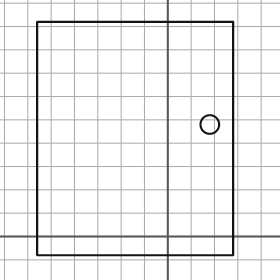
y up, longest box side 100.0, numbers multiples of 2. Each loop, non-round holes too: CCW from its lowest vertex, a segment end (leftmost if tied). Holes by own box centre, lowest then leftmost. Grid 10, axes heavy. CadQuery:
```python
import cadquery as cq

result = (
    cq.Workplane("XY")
    .moveTo(-56.0, -8.0)
    .lineTo(28.0, -8.0)
    .lineTo(28.0, 92.0)
    .lineTo(-56.0, 92.0)
    .close()
    .moveTo(18.0, 48.0)
    .circle(4.0)
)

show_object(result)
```